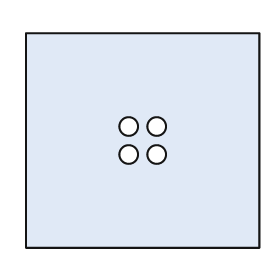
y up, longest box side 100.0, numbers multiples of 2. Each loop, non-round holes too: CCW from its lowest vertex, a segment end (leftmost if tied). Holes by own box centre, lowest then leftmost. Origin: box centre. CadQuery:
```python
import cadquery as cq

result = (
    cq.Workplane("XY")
    .moveTo(-50.0, -46.0)
    .lineTo(50.0, -46.0)
    .lineTo(50.0, 46.0)
    .lineTo(-50.0, 46.0)
    .close()
    .moveTo(-6.0, -6.0)
    .circle(4.0)
    .moveTo(6.0, -6.0)
    .circle(4.0)
    .moveTo(-6.0, 6.0)
    .circle(4.0)
    .moveTo(6.0, 6.0)
    .circle(4.0)
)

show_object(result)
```